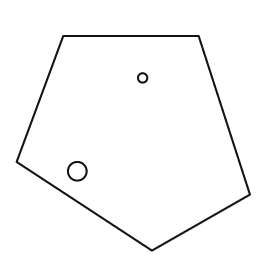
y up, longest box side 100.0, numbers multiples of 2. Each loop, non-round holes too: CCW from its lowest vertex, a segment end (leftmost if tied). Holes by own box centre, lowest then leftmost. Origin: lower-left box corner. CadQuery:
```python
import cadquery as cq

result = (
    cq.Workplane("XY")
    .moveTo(58.0, 0.0)
    .lineTo(100.0, 24.0)
    .lineTo(78.0, 92.0)
    .lineTo(20.0, 92.0)
    .lineTo(0.0, 38.0)
    .close()
    .moveTo(26.0, 34.0)
    .circle(4.0)
    .moveTo(54.0, 74.0)
    .circle(2.0)
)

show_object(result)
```